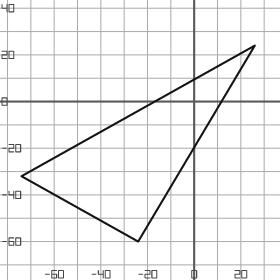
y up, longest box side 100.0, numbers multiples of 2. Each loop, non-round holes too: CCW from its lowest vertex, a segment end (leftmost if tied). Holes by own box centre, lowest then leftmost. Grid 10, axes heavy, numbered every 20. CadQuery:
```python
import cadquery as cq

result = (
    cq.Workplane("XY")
    .moveTo(-24.0, -60.0)
    .lineTo(26.0, 24.0)
    .lineTo(-74.0, -32.0)
    .close()
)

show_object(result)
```